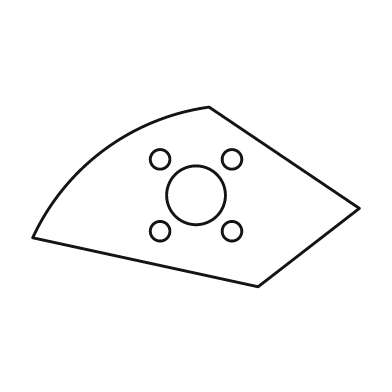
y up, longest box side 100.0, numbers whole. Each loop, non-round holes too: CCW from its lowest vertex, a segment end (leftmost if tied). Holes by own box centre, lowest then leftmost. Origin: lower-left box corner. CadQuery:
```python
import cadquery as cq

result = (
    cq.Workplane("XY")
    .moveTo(69.0, 0.0)
    .lineTo(100.0, 24.0)
    .lineTo(54.0, 55.0)
    .threePointArc((22.0, 42.0), (0.0, 15.0))
    .close()
    .moveTo(39.0, 17.0)
    .circle(3.0)
    .moveTo(61.0, 17.0)
    .circle(3.0)
    .moveTo(50.0, 28.0)
    .circle(9.0)
    .moveTo(39.0, 39.0)
    .circle(3.0)
    .moveTo(61.0, 39.0)
    .circle(3.0)
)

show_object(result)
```